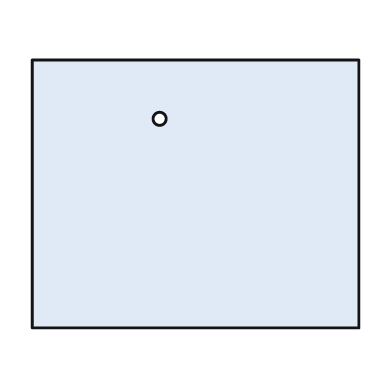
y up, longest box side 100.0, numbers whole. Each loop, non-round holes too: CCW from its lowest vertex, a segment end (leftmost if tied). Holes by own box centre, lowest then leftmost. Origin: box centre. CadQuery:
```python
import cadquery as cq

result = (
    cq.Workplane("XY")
    .moveTo(-50.0, -41.0)
    .lineTo(50.0, -41.0)
    .lineTo(50.0, 41.0)
    .lineTo(-50.0, 41.0)
    .close()
    .moveTo(-11.0, 23.0)
    .circle(2.0)
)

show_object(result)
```